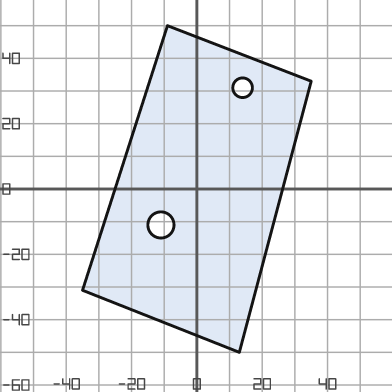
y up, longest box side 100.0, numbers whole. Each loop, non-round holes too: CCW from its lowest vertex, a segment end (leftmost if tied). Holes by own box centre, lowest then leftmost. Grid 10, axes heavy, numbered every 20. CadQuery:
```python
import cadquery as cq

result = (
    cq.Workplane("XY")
    .moveTo(13.0, -50.0)
    .lineTo(35.0, 33.0)
    .lineTo(-9.0, 50.0)
    .lineTo(-35.0, -31.0)
    .close()
    .moveTo(-11.0, -11.0)
    .circle(4.0)
    .moveTo(14.0, 31.0)
    .circle(3.0)
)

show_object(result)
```